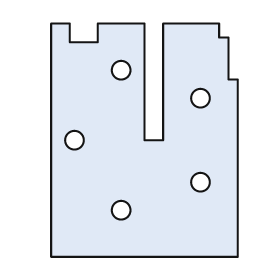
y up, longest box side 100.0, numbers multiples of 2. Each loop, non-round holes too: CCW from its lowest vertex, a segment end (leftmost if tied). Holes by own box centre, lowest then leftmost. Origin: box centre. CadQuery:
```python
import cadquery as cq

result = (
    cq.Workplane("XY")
    .moveTo(-40.0, -50.0)
    .lineTo(40.0, -50.0)
    .lineTo(40.0, 26.0)
    .lineTo(36.0, 26.0)
    .lineTo(36.0, 44.0)
    .lineTo(32.0, 44.0)
    .lineTo(32.0, 50.0)
    .lineTo(8.0, 50.0)
    .lineTo(8.0, 0.0)
    .lineTo(0.0, 0.0)
    .lineTo(0.0, 50.0)
    .lineTo(-20.0, 50.0)
    .lineTo(-20.0, 42.0)
    .lineTo(-32.0, 42.0)
    .lineTo(-32.0, 50.0)
    .lineTo(-40.0, 50.0)
    .close()
    .moveTo(-10.0, -30.0)
    .circle(4.0)
    .moveTo(24.0, -18.0)
    .circle(4.0)
    .moveTo(-30.0, 0.0)
    .circle(4.0)
    .moveTo(24.0, 18.0)
    .circle(4.0)
    .moveTo(-10.0, 30.0)
    .circle(4.0)
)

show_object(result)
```